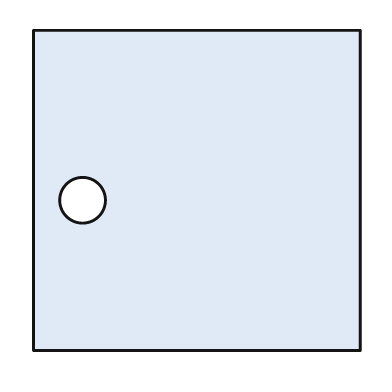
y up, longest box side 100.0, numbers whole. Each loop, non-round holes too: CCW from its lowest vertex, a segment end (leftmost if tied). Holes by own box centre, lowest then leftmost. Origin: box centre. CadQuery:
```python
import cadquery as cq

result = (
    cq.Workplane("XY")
    .moveTo(-50.0, -49.0)
    .lineTo(50.0, -49.0)
    .lineTo(50.0, 49.0)
    .lineTo(-50.0, 49.0)
    .close()
    .moveTo(-35.0, -3.0)
    .circle(7.0)
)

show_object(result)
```